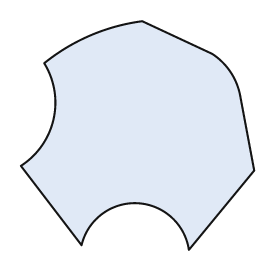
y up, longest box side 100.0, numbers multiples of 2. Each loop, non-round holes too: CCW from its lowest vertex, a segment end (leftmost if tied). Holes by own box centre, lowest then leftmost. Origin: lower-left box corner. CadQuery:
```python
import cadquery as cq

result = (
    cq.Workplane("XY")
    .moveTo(72.0, 0.0)
    .lineTo(100.0, 34.0)
    .lineTo(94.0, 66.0)
    .threePointArc((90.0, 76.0), (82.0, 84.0))
    .lineTo(52.0, 98.0)
    .threePointArc((30.0, 92.0), (10.0, 80.0))
    .threePointArc((14.0, 56.0), (0.0, 36.0))
    .lineTo(26.0, 2.0)
    .threePointArc((50.0, 20.0), (72.0, 0.0))
    .close()
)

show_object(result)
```